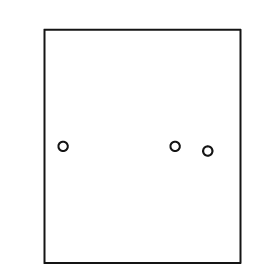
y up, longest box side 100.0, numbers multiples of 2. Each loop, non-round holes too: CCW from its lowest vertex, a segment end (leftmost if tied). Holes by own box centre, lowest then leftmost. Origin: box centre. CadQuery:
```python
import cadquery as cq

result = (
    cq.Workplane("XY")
    .moveTo(-42.0, -50.0)
    .lineTo(42.0, -50.0)
    .lineTo(42.0, 50.0)
    .lineTo(-42.0, 50.0)
    .close()
    .moveTo(28.0, -2.0)
    .circle(2.0)
    .moveTo(-34.0, 0.0)
    .circle(2.0)
    .moveTo(14.0, 0.0)
    .circle(2.0)
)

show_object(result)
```